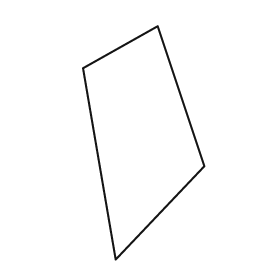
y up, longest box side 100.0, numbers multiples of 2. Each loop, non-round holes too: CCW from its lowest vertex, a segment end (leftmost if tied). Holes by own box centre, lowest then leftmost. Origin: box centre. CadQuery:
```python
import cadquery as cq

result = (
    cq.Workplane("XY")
    .moveTo(-12.0, -50.0)
    .lineTo(26.0, -10.0)
    .lineTo(6.0, 50.0)
    .lineTo(-26.0, 32.0)
    .close()
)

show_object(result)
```